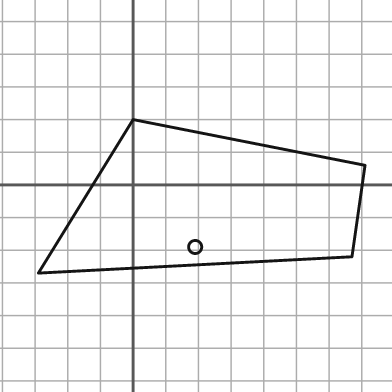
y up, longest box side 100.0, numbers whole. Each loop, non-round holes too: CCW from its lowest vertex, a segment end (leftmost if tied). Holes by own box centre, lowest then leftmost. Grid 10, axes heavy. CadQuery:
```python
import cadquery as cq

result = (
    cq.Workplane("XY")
    .moveTo(-29.0, -27.0)
    .lineTo(67.0, -22.0)
    .lineTo(71.0, 6.0)
    .lineTo(0.0, 20.0)
    .close()
    .moveTo(19.0, -19.0)
    .circle(2.0)
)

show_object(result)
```